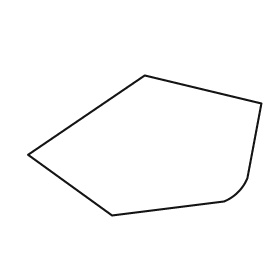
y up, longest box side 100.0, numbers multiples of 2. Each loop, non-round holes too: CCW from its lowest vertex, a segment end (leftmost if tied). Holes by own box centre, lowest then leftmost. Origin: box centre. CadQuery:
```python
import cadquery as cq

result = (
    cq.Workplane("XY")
    .moveTo(-14.0, -30.0)
    .lineTo(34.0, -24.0)
    .threePointArc((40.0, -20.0), (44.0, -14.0))
    .lineTo(50.0, 18.0)
    .lineTo(0.0, 30.0)
    .lineTo(-50.0, -4.0)
    .close()
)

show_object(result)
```